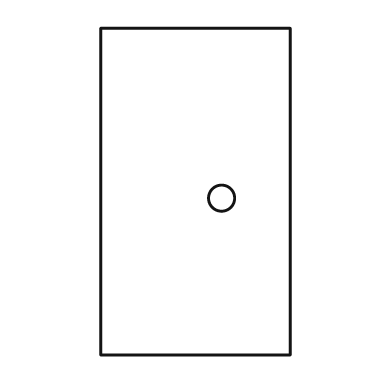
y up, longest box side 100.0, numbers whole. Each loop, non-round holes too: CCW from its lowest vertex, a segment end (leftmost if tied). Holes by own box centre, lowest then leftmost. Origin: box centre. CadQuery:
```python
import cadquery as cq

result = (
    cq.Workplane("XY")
    .moveTo(-29.0, -50.0)
    .lineTo(29.0, -50.0)
    .lineTo(29.0, 50.0)
    .lineTo(-29.0, 50.0)
    .close()
    .moveTo(8.0, -2.0)
    .circle(4.0)
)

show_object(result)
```